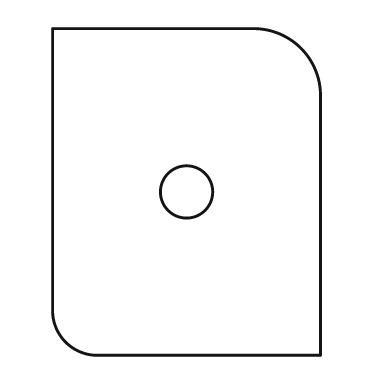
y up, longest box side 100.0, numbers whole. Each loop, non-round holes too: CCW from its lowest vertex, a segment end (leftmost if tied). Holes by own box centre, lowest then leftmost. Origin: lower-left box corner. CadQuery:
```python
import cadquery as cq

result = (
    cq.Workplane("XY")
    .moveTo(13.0, 0.0)
    .lineTo(82.0, 0.0)
    .lineTo(82.0, 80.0)
    .threePointArc((76.0, 94.0), (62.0, 100.0))
    .lineTo(0.0, 100.0)
    .lineTo(0.0, 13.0)
    .threePointArc((4.0, 4.0), (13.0, 0.0))
    .close()
    .moveTo(41.0, 50.0)
    .circle(8.0)
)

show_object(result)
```